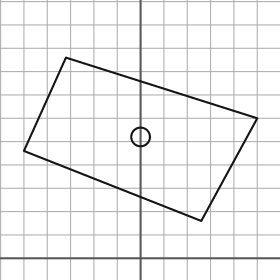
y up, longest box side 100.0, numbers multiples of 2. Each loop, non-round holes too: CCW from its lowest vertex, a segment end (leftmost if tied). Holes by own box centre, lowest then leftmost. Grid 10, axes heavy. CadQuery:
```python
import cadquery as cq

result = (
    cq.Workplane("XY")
    .moveTo(26.0, 16.0)
    .lineTo(50.0, 60.0)
    .lineTo(-32.0, 86.0)
    .lineTo(-50.0, 46.0)
    .close()
    .moveTo(0.0, 52.0)
    .circle(4.0)
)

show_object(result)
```